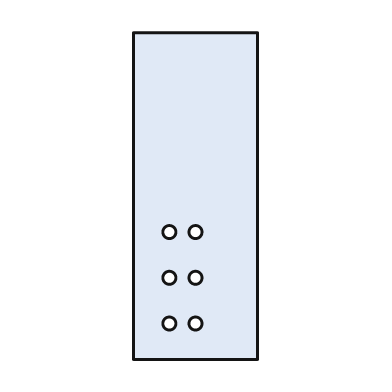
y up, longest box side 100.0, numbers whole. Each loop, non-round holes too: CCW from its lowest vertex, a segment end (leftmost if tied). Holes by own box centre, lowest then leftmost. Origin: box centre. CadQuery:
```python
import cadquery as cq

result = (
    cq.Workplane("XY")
    .moveTo(-19.0, -50.0)
    .lineTo(19.0, -50.0)
    .lineTo(19.0, 50.0)
    .lineTo(-19.0, 50.0)
    .close()
    .moveTo(-8.0, -39.0)
    .circle(2.0)
    .moveTo(0.0, -39.0)
    .circle(2.0)
    .moveTo(-8.0, -25.0)
    .circle(2.0)
    .moveTo(0.0, -25.0)
    .circle(2.0)
    .moveTo(-8.0, -11.0)
    .circle(2.0)
    .moveTo(0.0, -11.0)
    .circle(2.0)
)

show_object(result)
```